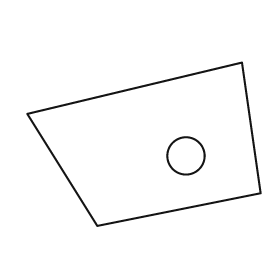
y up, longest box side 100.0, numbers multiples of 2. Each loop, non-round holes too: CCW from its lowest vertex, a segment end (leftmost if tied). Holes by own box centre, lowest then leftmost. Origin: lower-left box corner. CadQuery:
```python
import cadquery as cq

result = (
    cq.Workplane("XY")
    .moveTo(30.0, 0.0)
    .lineTo(100.0, 14.0)
    .lineTo(92.0, 70.0)
    .lineTo(0.0, 48.0)
    .close()
    .moveTo(68.0, 30.0)
    .circle(8.0)
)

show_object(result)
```